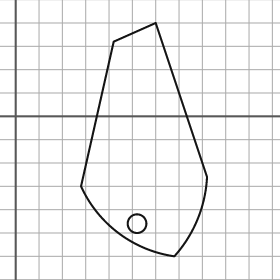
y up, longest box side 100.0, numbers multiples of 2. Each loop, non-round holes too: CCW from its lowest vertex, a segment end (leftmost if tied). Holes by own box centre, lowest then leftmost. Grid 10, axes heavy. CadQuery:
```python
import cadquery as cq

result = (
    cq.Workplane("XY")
    .moveTo(68.0, -60.0)
    .threePointArc((78.0, -44.0), (82.0, -26.0))
    .lineTo(60.0, 40.0)
    .lineTo(42.0, 32.0)
    .lineTo(28.0, -30.0)
    .threePointArc((44.0, -50.0), (68.0, -60.0))
    .close()
    .moveTo(52.0, -46.0)
    .circle(4.0)
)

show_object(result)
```